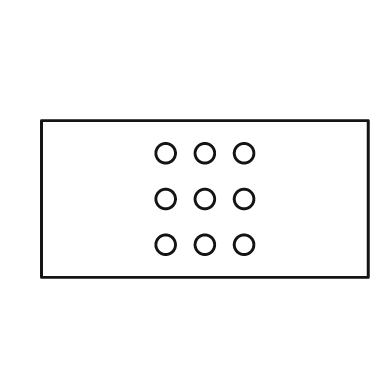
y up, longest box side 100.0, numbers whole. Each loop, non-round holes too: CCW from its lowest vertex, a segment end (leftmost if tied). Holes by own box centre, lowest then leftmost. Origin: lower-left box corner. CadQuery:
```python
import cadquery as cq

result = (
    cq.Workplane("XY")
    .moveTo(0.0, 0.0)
    .lineTo(100.0, 0.0)
    .lineTo(100.0, 48.0)
    .lineTo(0.0, 48.0)
    .close()
    .moveTo(38.0, 10.0)
    .circle(3.0)
    .moveTo(50.0, 10.0)
    .circle(3.0)
    .moveTo(62.0, 10.0)
    .circle(3.0)
    .moveTo(38.0, 24.0)
    .circle(3.0)
    .moveTo(50.0, 24.0)
    .circle(3.0)
    .moveTo(62.0, 24.0)
    .circle(3.0)
    .moveTo(38.0, 38.0)
    .circle(3.0)
    .moveTo(50.0, 38.0)
    .circle(3.0)
    .moveTo(62.0, 38.0)
    .circle(3.0)
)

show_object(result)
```